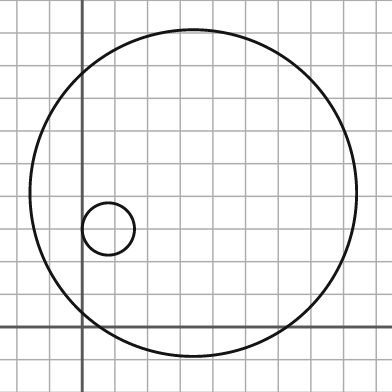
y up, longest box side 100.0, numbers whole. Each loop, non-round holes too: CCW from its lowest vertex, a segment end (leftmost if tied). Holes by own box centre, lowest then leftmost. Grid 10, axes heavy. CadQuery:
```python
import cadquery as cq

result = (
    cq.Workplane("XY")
    .moveTo(34.0, 41.0)
    .circle(50.0)
    .moveTo(8.0, 30.0)
    .circle(8.0)
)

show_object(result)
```